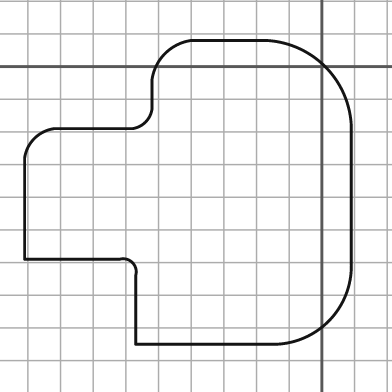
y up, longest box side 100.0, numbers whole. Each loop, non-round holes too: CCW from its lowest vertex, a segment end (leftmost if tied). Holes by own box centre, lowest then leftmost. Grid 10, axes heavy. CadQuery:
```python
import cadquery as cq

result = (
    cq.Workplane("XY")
    .moveTo(-57.0, -85.0)
    .lineTo(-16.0, -85.0)
    .threePointArc((2.0, -78.0), (9.0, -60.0))
    .lineTo(9.0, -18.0)
    .threePointArc((1.0, 0.0), (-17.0, 8.0))
    .lineTo(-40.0, 8.0)
    .threePointArc((-48.0, 4.0), (-52.0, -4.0))
    .lineTo(-52.0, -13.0)
    .threePointArc((-54.0, -17.0), (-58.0, -19.0))
    .lineTo(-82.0, -19.0)
    .threePointArc((-88.0, -22.0), (-91.0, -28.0))
    .lineTo(-91.0, -59.0)
    .lineTo(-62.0, -59.0)
    .threePointArc((-58.0, -60.0), (-57.0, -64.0))
    .close()
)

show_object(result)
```